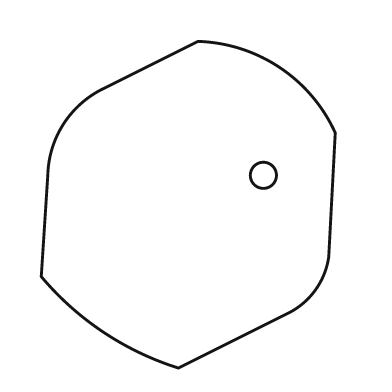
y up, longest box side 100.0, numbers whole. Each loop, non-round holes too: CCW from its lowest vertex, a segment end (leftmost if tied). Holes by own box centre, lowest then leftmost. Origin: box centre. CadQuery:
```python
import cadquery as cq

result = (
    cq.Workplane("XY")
    .moveTo(-3.0, -50.0)
    .lineTo(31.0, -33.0)
    .threePointArc((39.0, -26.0), (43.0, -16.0))
    .lineTo(45.0, 22.0)
    .threePointArc((28.0, 42.0), (3.0, 50.0))
    .lineTo(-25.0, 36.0)
    .threePointArc((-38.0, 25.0), (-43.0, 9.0))
    .lineTo(-45.0, -22.0)
    .threePointArc((-26.0, -39.0), (-3.0, -50.0))
    .close()
    .moveTo(23.0, 9.0)
    .circle(4.0)
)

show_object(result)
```